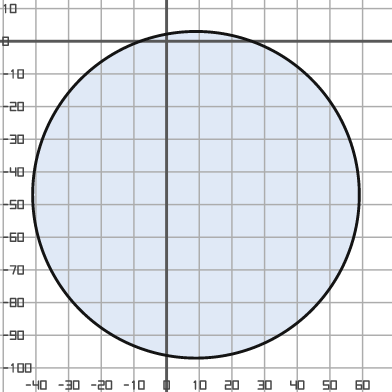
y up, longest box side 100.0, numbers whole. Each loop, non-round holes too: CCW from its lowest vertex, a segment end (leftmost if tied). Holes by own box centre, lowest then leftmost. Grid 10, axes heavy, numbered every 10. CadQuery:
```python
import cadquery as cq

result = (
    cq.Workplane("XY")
    .moveTo(9.0, -47.0)
    .circle(50.0)
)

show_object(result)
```